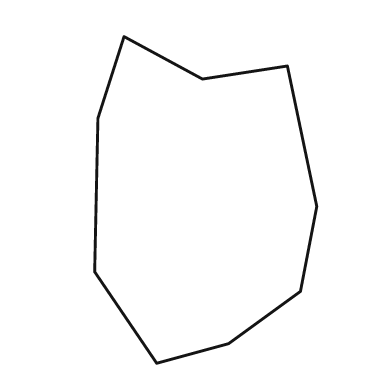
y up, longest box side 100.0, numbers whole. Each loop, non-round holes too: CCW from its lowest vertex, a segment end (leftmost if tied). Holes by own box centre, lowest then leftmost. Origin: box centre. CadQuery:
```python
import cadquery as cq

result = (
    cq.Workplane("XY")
    .moveTo(-15.0, -50.0)
    .lineTo(7.0, -44.0)
    .lineTo(29.0, -28.0)
    .lineTo(34.0, -2.0)
    .lineTo(25.0, 41.0)
    .lineTo(-1.0, 37.0)
    .lineTo(-25.0, 50.0)
    .lineTo(-33.0, 25.0)
    .lineTo(-34.0, -22.0)
    .close()
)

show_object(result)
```